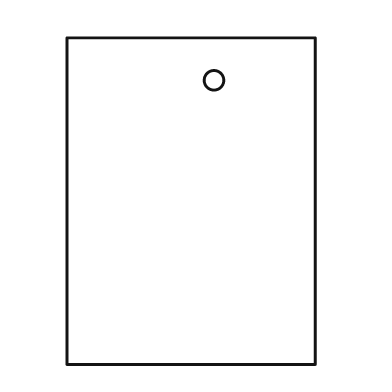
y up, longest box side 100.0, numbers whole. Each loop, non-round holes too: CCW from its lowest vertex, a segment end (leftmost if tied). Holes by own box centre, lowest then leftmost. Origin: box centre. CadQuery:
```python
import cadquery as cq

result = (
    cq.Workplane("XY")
    .moveTo(-38.0, -50.0)
    .lineTo(38.0, -50.0)
    .lineTo(38.0, 50.0)
    .lineTo(-38.0, 50.0)
    .close()
    .moveTo(7.0, 37.0)
    .circle(3.0)
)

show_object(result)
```